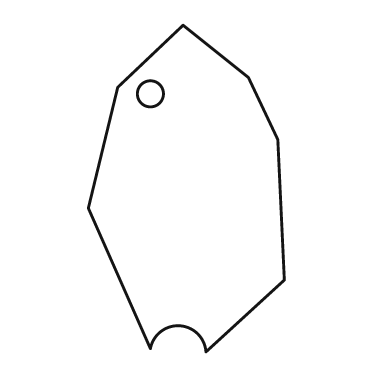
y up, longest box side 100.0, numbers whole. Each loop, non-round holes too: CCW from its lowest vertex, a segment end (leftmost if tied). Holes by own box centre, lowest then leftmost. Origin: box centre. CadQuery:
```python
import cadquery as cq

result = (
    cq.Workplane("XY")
    .moveTo(6.0, -50.0)
    .lineTo(30.0, -28.0)
    .lineTo(28.0, 15.0)
    .lineTo(19.0, 34.0)
    .lineTo(-1.0, 50.0)
    .lineTo(-21.0, 31.0)
    .lineTo(-30.0, -6.0)
    .lineTo(-11.0, -49.0)
    .threePointArc((-2.0, -42.0), (6.0, -50.0))
    .close()
    .moveTo(-11.0, 29.0)
    .circle(4.0)
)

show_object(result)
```